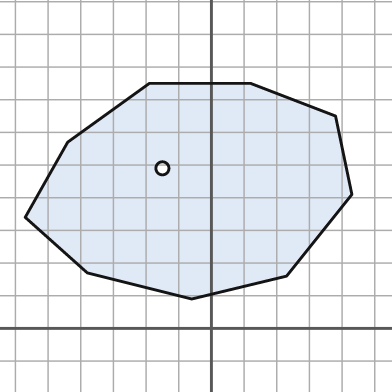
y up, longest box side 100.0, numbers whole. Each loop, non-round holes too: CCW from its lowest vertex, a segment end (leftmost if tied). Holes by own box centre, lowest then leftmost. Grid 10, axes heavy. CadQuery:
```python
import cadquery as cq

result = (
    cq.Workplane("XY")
    .moveTo(-6.0, 9.0)
    .lineTo(23.0, 16.0)
    .lineTo(43.0, 41.0)
    .lineTo(38.0, 65.0)
    .lineTo(12.0, 75.0)
    .lineTo(-19.0, 75.0)
    .lineTo(-44.0, 57.0)
    .lineTo(-57.0, 34.0)
    .lineTo(-38.0, 17.0)
    .close()
    .moveTo(-15.0, 49.0)
    .circle(2.0)
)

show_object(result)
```